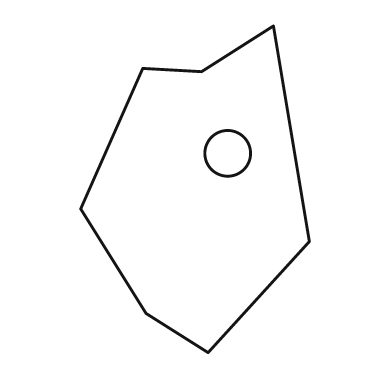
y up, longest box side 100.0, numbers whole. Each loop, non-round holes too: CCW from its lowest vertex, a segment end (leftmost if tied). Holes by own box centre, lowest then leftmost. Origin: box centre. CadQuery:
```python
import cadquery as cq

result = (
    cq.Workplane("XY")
    .moveTo(4.0, -50.0)
    .lineTo(35.0, -16.0)
    .lineTo(24.0, 50.0)
    .lineTo(2.0, 36.0)
    .lineTo(-16.0, 37.0)
    .lineTo(-35.0, -6.0)
    .lineTo(-15.0, -38.0)
    .close()
    .moveTo(10.0, 11.0)
    .circle(7.0)
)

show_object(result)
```